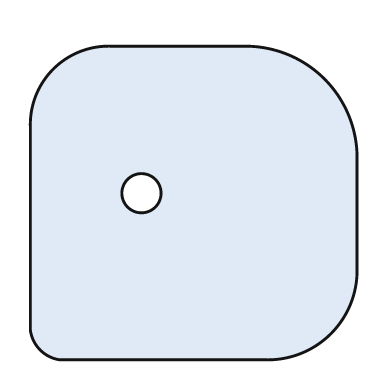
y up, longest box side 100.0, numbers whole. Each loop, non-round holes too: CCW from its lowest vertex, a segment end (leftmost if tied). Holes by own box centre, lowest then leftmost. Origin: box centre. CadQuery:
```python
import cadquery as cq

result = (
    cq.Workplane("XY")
    .moveTo(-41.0, -48.0)
    .lineTo(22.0, -48.0)
    .threePointArc((42.0, -40.0), (50.0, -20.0))
    .lineTo(50.0, 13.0)
    .threePointArc((40.0, 38.0), (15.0, 48.0))
    .lineTo(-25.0, 48.0)
    .threePointArc((-43.0, 41.0), (-50.0, 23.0))
    .lineTo(-50.0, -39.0)
    .threePointArc((-47.0, -45.0), (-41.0, -48.0))
    .close()
    .moveTo(-16.0, 3.0)
    .circle(6.0)
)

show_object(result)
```